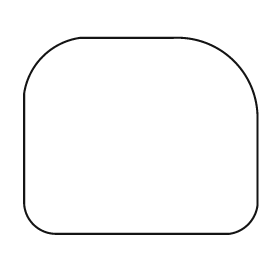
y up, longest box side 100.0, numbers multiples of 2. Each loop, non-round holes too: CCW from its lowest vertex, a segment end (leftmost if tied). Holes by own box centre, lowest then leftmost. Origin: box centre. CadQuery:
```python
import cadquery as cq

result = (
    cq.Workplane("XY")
    .moveTo(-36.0, -42.0)
    .lineTo(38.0, -42.0)
    .threePointArc((46.0, -38.0), (50.0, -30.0))
    .lineTo(50.0, 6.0)
    .threePointArc((40.0, 32.0), (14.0, 42.0))
    .lineTo(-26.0, 42.0)
    .threePointArc((-42.0, 34.0), (-50.0, 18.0))
    .lineTo(-50.0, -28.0)
    .threePointArc((-46.0, -38.0), (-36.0, -42.0))
    .close()
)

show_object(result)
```